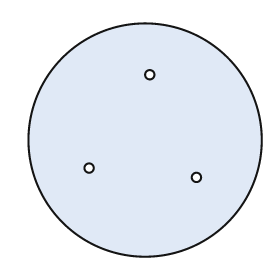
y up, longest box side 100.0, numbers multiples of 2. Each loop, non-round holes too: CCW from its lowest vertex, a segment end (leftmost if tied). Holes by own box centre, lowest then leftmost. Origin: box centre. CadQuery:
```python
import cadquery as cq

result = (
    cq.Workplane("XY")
    .moveTo(0.0, 0.0)
    .circle(50.0)
    .moveTo(22.0, -16.0)
    .circle(2.0)
    .moveTo(-24.0, -12.0)
    .circle(2.0)
    .moveTo(2.0, 28.0)
    .circle(2.0)
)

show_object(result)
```